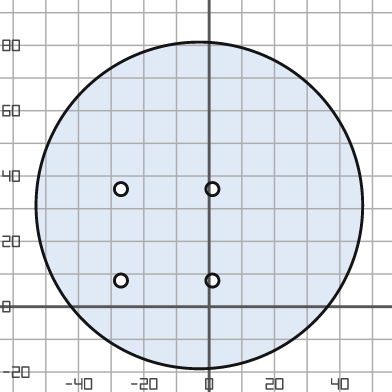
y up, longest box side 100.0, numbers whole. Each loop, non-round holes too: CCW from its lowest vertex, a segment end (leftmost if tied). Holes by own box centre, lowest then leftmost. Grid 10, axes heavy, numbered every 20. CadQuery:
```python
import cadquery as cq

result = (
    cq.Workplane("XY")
    .moveTo(-3.0, 31.0)
    .circle(50.0)
    .moveTo(-27.0, 8.0)
    .circle(2.0)
    .moveTo(1.0, 8.0)
    .circle(2.0)
    .moveTo(-27.0, 36.0)
    .circle(2.0)
    .moveTo(1.0, 36.0)
    .circle(2.0)
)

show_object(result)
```